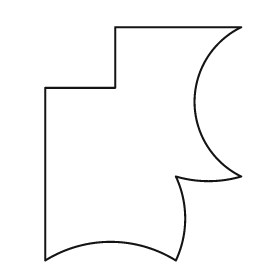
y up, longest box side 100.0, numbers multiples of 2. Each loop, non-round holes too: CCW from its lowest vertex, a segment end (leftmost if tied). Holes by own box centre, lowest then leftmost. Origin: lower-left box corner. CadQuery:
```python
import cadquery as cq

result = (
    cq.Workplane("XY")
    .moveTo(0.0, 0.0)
    .threePointArc((28.0, 8.0), (56.0, 0.0))
    .threePointArc((60.0, 18.0), (56.0, 36.0))
    .threePointArc((70.0, 34.0), (84.0, 36.0))
    .threePointArc((64.0, 68.0), (84.0, 100.0))
    .lineTo(30.0, 100.0)
    .lineTo(30.0, 74.0)
    .lineTo(0.0, 74.0)
    .close()
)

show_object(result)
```